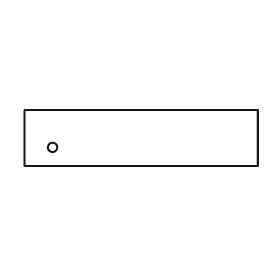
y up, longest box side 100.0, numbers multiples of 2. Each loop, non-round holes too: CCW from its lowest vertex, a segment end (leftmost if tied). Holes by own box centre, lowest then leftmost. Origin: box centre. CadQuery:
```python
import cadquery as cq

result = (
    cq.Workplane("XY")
    .moveTo(-50.0, -12.0)
    .lineTo(50.0, -12.0)
    .lineTo(50.0, 12.0)
    .lineTo(-50.0, 12.0)
    .close()
    .moveTo(-38.0, -4.0)
    .circle(2.0)
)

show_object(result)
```